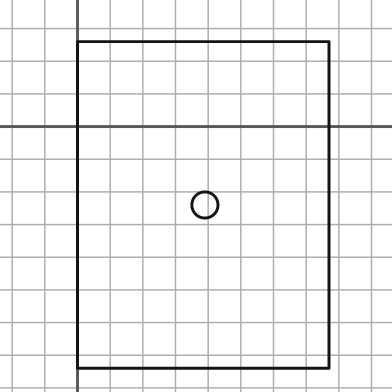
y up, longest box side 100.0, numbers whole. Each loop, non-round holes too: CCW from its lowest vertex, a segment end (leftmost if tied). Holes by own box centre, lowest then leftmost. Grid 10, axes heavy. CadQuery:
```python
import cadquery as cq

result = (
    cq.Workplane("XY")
    .moveTo(0.0, -74.0)
    .lineTo(77.0, -74.0)
    .lineTo(77.0, 26.0)
    .lineTo(0.0, 26.0)
    .close()
    .moveTo(39.0, -24.0)
    .circle(4.0)
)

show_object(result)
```